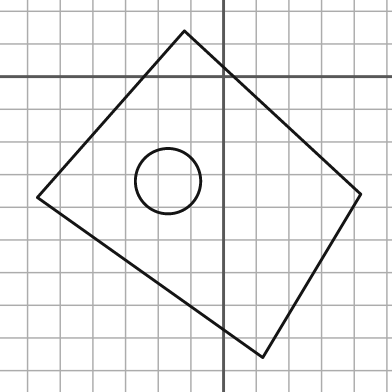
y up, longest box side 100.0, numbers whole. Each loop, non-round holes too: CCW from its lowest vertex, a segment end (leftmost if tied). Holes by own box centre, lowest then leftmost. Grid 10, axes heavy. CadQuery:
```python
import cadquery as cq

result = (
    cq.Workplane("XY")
    .moveTo(12.0, -86.0)
    .lineTo(42.0, -36.0)
    .lineTo(-12.0, 14.0)
    .lineTo(-57.0, -37.0)
    .close()
    .moveTo(-17.0, -32.0)
    .circle(10.0)
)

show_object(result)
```